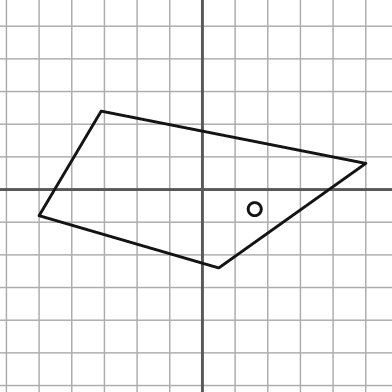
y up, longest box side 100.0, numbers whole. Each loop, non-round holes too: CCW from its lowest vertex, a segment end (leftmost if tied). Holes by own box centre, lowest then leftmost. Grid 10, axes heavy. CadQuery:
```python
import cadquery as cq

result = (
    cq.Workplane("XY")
    .moveTo(5.0, -24.0)
    .lineTo(50.0, 8.0)
    .lineTo(-31.0, 24.0)
    .lineTo(-50.0, -8.0)
    .close()
    .moveTo(16.0, -6.0)
    .circle(2.0)
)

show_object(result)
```